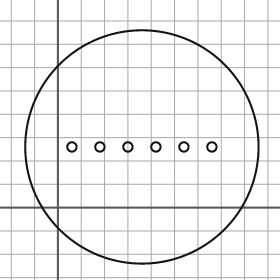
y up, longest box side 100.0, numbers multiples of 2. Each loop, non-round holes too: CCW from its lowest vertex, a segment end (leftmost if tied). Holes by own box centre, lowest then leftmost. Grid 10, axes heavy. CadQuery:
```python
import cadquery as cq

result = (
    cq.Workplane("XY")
    .moveTo(36.0, 26.0)
    .circle(50.0)
    .moveTo(6.0, 26.0)
    .circle(2.0)
    .moveTo(18.0, 26.0)
    .circle(2.0)
    .moveTo(30.0, 26.0)
    .circle(2.0)
    .moveTo(42.0, 26.0)
    .circle(2.0)
    .moveTo(54.0, 26.0)
    .circle(2.0)
    .moveTo(66.0, 26.0)
    .circle(2.0)
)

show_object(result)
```